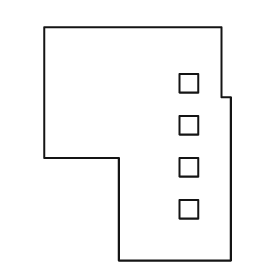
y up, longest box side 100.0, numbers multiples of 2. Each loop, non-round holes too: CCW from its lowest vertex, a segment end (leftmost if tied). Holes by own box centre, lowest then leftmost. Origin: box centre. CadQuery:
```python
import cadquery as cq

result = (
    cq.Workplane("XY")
    .moveTo(-8.0, -50.0)
    .lineTo(40.0, -50.0)
    .lineTo(40.0, 20.0)
    .lineTo(36.0, 20.0)
    .lineTo(36.0, 50.0)
    .lineTo(-40.0, 50.0)
    .lineTo(-40.0, -6.0)
    .lineTo(-8.0, -6.0)
    .close()
    .moveTo(18.0, -32.0)
    .lineTo(26.0, -32.0)
    .lineTo(26.0, -24.0)
    .lineTo(18.0, -24.0)
    .close()
    .moveTo(18.0, -14.0)
    .lineTo(26.0, -14.0)
    .lineTo(26.0, -6.0)
    .lineTo(18.0, -6.0)
    .close()
    .moveTo(18.0, 4.0)
    .lineTo(26.0, 4.0)
    .lineTo(26.0, 12.0)
    .lineTo(18.0, 12.0)
    .close()
    .moveTo(18.0, 22.0)
    .lineTo(26.0, 22.0)
    .lineTo(26.0, 30.0)
    .lineTo(18.0, 30.0)
    .close()
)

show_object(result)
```